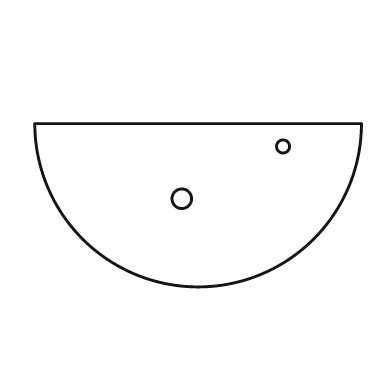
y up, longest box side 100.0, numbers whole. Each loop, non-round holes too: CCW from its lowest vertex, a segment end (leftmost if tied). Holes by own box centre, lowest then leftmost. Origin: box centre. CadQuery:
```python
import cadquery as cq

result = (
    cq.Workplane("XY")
    .moveTo(-50.0, 25.0)
    .threePointArc((0.0, -25.0), (50.0, 25.0))
    .close()
    .moveTo(-5.0, 2.0)
    .circle(3.0)
    .moveTo(26.0, 18.0)
    .circle(2.0)
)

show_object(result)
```